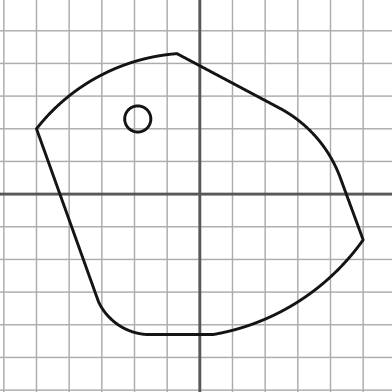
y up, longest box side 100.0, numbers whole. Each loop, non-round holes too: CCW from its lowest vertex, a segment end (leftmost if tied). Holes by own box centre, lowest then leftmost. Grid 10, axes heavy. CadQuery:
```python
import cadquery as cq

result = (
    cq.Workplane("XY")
    .moveTo(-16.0, -43.0)
    .lineTo(4.0, -43.0)
    .threePointArc((30.0, -33.0), (50.0, -14.0))
    .lineTo(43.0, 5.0)
    .threePointArc((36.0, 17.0), (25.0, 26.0))
    .lineTo(-7.0, 43.0)
    .threePointArc((-31.0, 36.0), (-50.0, 20.0))
    .lineTo(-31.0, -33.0)
    .threePointArc((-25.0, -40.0), (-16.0, -43.0))
    .close()
    .moveTo(-19.0, 23.0)
    .circle(4.0)
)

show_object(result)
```